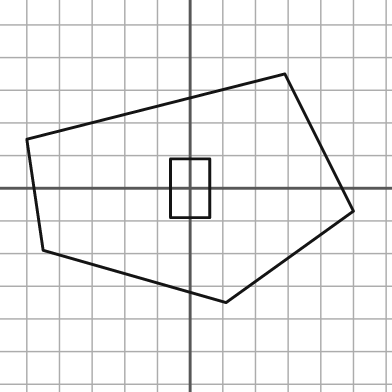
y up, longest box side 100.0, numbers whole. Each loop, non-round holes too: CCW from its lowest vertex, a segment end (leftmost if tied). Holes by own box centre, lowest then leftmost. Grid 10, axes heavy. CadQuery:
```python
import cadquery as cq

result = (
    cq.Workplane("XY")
    .moveTo(11.0, -35.0)
    .lineTo(50.0, -7.0)
    .lineTo(29.0, 35.0)
    .lineTo(-50.0, 15.0)
    .lineTo(-45.0, -19.0)
    .close()
    .moveTo(-6.0, -9.0)
    .lineTo(6.0, -9.0)
    .lineTo(6.0, 9.0)
    .lineTo(-6.0, 9.0)
    .close()
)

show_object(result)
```